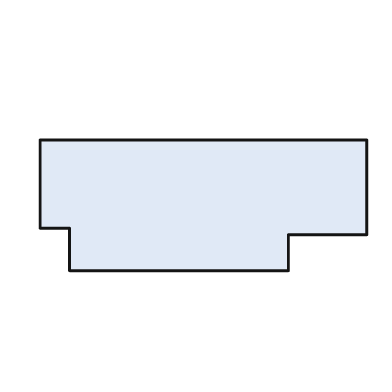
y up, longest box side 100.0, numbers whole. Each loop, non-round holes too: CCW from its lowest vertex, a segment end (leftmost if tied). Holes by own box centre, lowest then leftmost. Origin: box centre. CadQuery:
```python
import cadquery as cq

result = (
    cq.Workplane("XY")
    .moveTo(-41.0, -20.0)
    .lineTo(26.0, -20.0)
    .lineTo(26.0, -9.0)
    .lineTo(50.0, -9.0)
    .lineTo(50.0, 20.0)
    .lineTo(-50.0, 20.0)
    .lineTo(-50.0, -7.0)
    .lineTo(-41.0, -7.0)
    .close()
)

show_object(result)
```